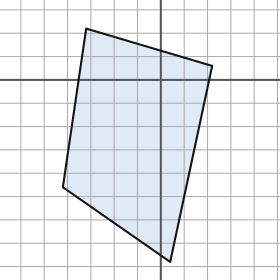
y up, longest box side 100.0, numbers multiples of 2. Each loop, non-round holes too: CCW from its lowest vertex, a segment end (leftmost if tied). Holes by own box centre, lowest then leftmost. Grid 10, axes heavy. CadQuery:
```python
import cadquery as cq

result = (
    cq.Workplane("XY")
    .moveTo(4.0, -78.0)
    .lineTo(22.0, 6.0)
    .lineTo(-32.0, 22.0)
    .lineTo(-42.0, -46.0)
    .close()
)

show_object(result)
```